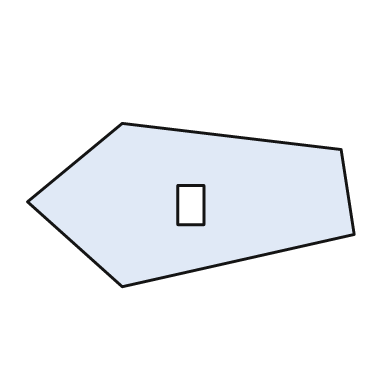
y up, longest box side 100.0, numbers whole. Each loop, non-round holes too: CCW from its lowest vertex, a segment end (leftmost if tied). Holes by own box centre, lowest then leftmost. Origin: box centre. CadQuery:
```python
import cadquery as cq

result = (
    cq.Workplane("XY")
    .moveTo(-21.0, -25.0)
    .lineTo(50.0, -9.0)
    .lineTo(46.0, 17.0)
    .lineTo(-21.0, 25.0)
    .lineTo(-50.0, 1.0)
    .close()
    .moveTo(-4.0, -6.0)
    .lineTo(4.0, -6.0)
    .lineTo(4.0, 6.0)
    .lineTo(-4.0, 6.0)
    .close()
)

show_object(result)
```